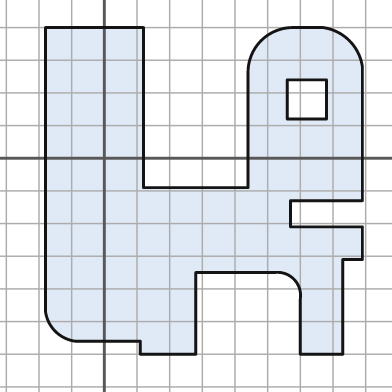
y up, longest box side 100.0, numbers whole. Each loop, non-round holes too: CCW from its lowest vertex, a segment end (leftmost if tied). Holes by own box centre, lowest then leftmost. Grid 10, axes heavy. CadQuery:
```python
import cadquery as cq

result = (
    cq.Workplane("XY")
    .moveTo(11.0, -60.0)
    .lineTo(28.0, -60.0)
    .lineTo(28.0, -35.0)
    .lineTo(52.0, -35.0)
    .threePointArc((58.0, -37.0), (60.0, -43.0))
    .lineTo(60.0, -60.0)
    .lineTo(73.0, -60.0)
    .lineTo(73.0, -31.0)
    .lineTo(79.0, -31.0)
    .lineTo(79.0, -21.0)
    .lineTo(57.0, -21.0)
    .lineTo(57.0, -13.0)
    .lineTo(79.0, -13.0)
    .lineTo(79.0, 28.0)
    .threePointArc((75.0, 36.0), (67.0, 40.0))
    .lineTo(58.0, 40.0)
    .threePointArc((48.0, 36.0), (44.0, 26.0))
    .lineTo(44.0, -9.0)
    .lineTo(12.0, -9.0)
    .lineTo(12.0, 40.0)
    .lineTo(-18.0, 40.0)
    .lineTo(-18.0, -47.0)
    .threePointArc((-15.0, -53.0), (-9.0, -56.0))
    .lineTo(11.0, -56.0)
    .close()
    .moveTo(56.0, 12.0)
    .lineTo(68.0, 12.0)
    .lineTo(68.0, 24.0)
    .lineTo(56.0, 24.0)
    .close()
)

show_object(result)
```